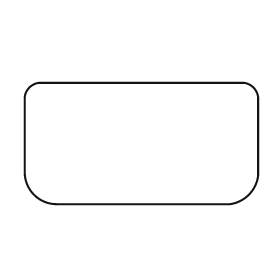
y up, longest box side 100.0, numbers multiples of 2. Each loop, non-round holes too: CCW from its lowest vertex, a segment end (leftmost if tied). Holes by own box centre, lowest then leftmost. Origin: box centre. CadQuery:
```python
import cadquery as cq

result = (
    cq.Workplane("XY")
    .moveTo(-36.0, -26.0)
    .lineTo(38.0, -26.0)
    .threePointArc((46.0, -22.0), (50.0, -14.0))
    .lineTo(50.0, 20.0)
    .threePointArc((48.0, 24.0), (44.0, 26.0))
    .lineTo(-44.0, 26.0)
    .threePointArc((-48.0, 24.0), (-50.0, 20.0))
    .lineTo(-50.0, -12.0)
    .threePointArc((-46.0, -22.0), (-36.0, -26.0))
    .close()
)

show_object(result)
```